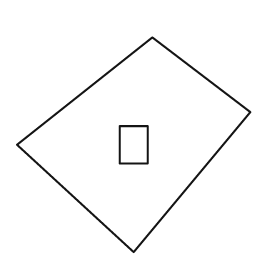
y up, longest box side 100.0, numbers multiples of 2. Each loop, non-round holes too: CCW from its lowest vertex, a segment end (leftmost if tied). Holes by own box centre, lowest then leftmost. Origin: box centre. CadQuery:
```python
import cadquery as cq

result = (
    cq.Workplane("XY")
    .moveTo(0.0, -46.0)
    .lineTo(50.0, 14.0)
    .lineTo(8.0, 46.0)
    .lineTo(-50.0, 0.0)
    .close()
    .moveTo(-6.0, -8.0)
    .lineTo(6.0, -8.0)
    .lineTo(6.0, 8.0)
    .lineTo(-6.0, 8.0)
    .close()
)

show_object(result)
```